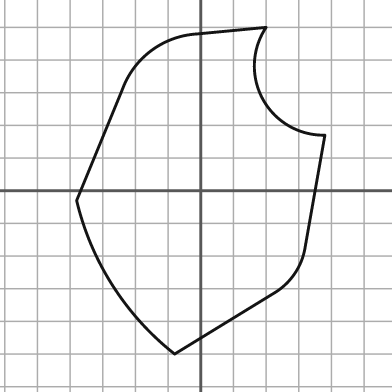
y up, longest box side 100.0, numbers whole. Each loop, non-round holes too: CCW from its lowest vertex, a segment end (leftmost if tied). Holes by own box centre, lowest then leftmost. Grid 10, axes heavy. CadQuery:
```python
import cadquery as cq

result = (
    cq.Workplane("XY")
    .moveTo(-8.0, -50.0)
    .lineTo(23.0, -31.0)
    .threePointArc((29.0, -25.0), (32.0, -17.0))
    .lineTo(38.0, 17.0)
    .threePointArc((19.0, 28.0), (20.0, 50.0))
    .lineTo(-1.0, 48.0)
    .threePointArc((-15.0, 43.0), (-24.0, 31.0))
    .lineTo(-38.0, -3.0)
    .threePointArc((-27.0, -29.0), (-8.0, -50.0))
    .close()
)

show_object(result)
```